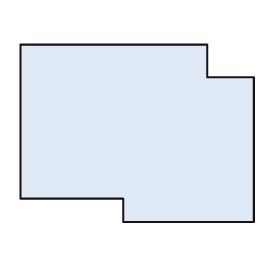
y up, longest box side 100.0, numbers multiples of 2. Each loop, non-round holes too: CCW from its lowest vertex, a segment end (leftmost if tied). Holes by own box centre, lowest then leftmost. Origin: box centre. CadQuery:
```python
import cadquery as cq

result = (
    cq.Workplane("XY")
    .moveTo(-6.0, -38.0)
    .lineTo(50.0, -38.0)
    .lineTo(50.0, 24.0)
    .lineTo(30.0, 24.0)
    .lineTo(30.0, 38.0)
    .lineTo(-50.0, 38.0)
    .lineTo(-50.0, -28.0)
    .lineTo(-6.0, -28.0)
    .close()
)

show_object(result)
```